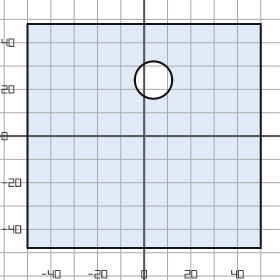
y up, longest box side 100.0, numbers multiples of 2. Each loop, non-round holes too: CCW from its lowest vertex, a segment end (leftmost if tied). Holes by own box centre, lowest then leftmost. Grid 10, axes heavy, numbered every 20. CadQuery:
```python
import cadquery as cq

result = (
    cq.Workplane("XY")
    .moveTo(-50.0, -48.0)
    .lineTo(50.0, -48.0)
    .lineTo(50.0, 48.0)
    .lineTo(-50.0, 48.0)
    .close()
    .moveTo(4.0, 24.0)
    .circle(8.0)
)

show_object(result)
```